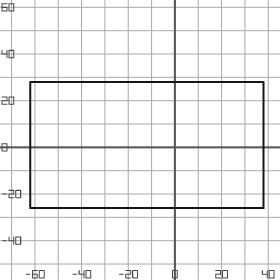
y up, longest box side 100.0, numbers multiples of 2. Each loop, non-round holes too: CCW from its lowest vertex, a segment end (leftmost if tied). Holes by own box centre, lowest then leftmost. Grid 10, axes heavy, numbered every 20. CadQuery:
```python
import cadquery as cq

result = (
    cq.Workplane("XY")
    .moveTo(-62.0, -26.0)
    .lineTo(38.0, -26.0)
    .lineTo(38.0, 28.0)
    .lineTo(-62.0, 28.0)
    .close()
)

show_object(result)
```